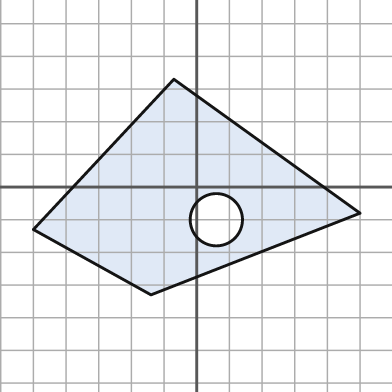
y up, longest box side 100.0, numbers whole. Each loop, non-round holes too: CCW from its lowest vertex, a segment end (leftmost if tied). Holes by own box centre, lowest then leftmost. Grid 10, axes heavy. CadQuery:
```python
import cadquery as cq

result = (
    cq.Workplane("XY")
    .moveTo(-14.0, -33.0)
    .lineTo(50.0, -8.0)
    .lineTo(-7.0, 33.0)
    .lineTo(-50.0, -13.0)
    .close()
    .moveTo(6.0, -10.0)
    .circle(8.0)
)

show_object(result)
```